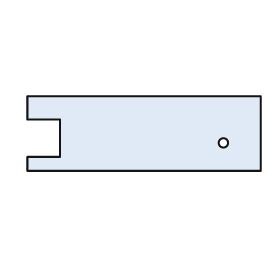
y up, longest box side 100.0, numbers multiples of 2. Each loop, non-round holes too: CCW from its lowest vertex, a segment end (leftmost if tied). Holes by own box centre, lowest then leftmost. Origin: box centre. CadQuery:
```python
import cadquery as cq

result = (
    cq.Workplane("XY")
    .moveTo(-50.0, -16.0)
    .lineTo(50.0, -16.0)
    .lineTo(50.0, 16.0)
    .lineTo(-50.0, 16.0)
    .lineTo(-50.0, 6.0)
    .lineTo(-36.0, 6.0)
    .lineTo(-36.0, -10.0)
    .lineTo(-50.0, -10.0)
    .close()
    .moveTo(34.0, -4.0)
    .circle(2.0)
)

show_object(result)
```